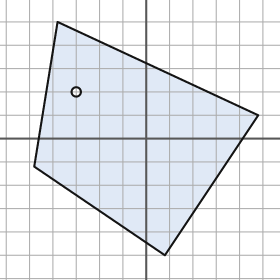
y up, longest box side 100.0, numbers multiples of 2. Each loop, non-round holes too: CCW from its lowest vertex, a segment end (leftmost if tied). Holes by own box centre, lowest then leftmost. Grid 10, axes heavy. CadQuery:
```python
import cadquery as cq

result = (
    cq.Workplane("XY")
    .moveTo(8.0, -50.0)
    .lineTo(48.0, 10.0)
    .lineTo(-38.0, 50.0)
    .lineTo(-48.0, -12.0)
    .close()
    .moveTo(-30.0, 20.0)
    .circle(2.0)
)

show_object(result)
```